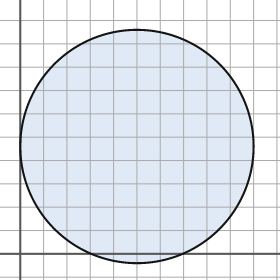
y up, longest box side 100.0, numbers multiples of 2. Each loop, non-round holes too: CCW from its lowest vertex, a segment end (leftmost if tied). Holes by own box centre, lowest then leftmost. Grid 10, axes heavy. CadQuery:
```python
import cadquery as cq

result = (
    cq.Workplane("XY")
    .moveTo(50.0, 46.0)
    .circle(50.0)
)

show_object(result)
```